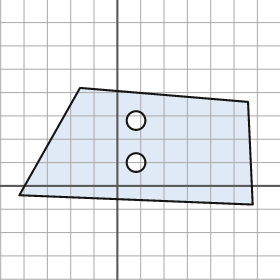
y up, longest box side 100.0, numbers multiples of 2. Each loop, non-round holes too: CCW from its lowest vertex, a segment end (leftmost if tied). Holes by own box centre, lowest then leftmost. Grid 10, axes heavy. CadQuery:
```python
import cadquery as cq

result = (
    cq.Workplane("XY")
    .moveTo(58.0, -8.0)
    .lineTo(56.0, 36.0)
    .lineTo(-16.0, 42.0)
    .lineTo(-42.0, -4.0)
    .close()
    .moveTo(8.0, 10.0)
    .circle(4.0)
    .moveTo(8.0, 28.0)
    .circle(4.0)
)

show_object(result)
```